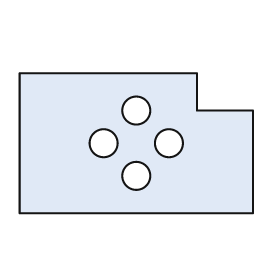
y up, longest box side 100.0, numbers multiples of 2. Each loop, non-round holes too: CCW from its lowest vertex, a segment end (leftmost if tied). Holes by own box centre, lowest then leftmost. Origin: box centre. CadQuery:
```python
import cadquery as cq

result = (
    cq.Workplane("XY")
    .moveTo(-50.0, -30.0)
    .lineTo(50.0, -30.0)
    .lineTo(50.0, 14.0)
    .lineTo(26.0, 14.0)
    .lineTo(26.0, 30.0)
    .lineTo(-50.0, 30.0)
    .close()
    .moveTo(0.0, -14.0)
    .circle(6.0)
    .moveTo(-14.0, 0.0)
    .circle(6.0)
    .moveTo(14.0, 0.0)
    .circle(6.0)
    .moveTo(0.0, 14.0)
    .circle(6.0)
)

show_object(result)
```